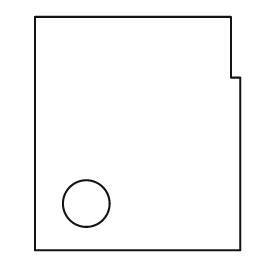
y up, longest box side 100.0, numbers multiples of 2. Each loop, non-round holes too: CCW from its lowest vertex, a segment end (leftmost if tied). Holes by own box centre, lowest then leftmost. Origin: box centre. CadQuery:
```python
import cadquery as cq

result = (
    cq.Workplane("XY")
    .moveTo(-44.0, -50.0)
    .lineTo(44.0, -50.0)
    .lineTo(44.0, 24.0)
    .lineTo(40.0, 24.0)
    .lineTo(40.0, 50.0)
    .lineTo(-44.0, 50.0)
    .close()
    .moveTo(-22.0, -30.0)
    .circle(10.0)
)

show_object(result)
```